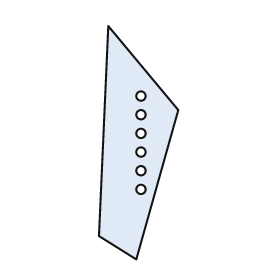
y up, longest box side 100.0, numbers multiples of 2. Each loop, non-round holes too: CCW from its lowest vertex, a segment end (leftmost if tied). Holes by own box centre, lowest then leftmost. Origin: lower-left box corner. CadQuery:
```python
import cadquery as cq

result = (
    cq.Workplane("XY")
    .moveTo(16.0, 0.0)
    .lineTo(34.0, 64.0)
    .lineTo(4.0, 100.0)
    .lineTo(0.0, 10.0)
    .close()
    .moveTo(18.0, 30.0)
    .circle(2.0)
    .moveTo(18.0, 38.0)
    .circle(2.0)
    .moveTo(18.0, 46.0)
    .circle(2.0)
    .moveTo(18.0, 54.0)
    .circle(2.0)
    .moveTo(18.0, 62.0)
    .circle(2.0)
    .moveTo(18.0, 70.0)
    .circle(2.0)
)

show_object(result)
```